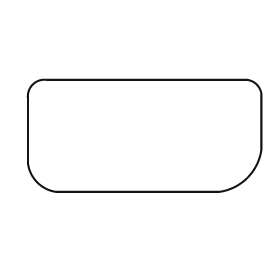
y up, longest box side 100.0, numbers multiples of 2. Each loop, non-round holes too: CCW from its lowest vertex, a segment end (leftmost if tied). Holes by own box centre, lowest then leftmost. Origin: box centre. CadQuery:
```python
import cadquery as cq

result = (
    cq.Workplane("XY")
    .moveTo(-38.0, -24.0)
    .lineTo(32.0, -24.0)
    .threePointArc((44.0, -18.0), (50.0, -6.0))
    .lineTo(50.0, 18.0)
    .threePointArc((48.0, 22.0), (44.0, 24.0))
    .lineTo(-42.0, 24.0)
    .threePointArc((-48.0, 22.0), (-50.0, 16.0))
    .lineTo(-50.0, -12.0)
    .threePointArc((-46.0, -20.0), (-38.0, -24.0))
    .close()
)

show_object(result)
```